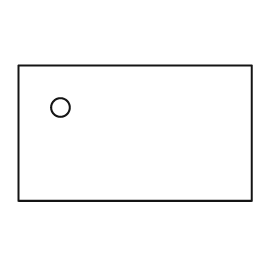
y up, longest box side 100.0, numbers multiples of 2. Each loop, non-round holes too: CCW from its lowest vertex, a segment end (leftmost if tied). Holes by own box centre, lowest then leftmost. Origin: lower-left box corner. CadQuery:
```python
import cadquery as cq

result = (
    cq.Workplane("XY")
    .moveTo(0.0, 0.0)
    .lineTo(100.0, 0.0)
    .lineTo(100.0, 58.0)
    .lineTo(0.0, 58.0)
    .close()
    .moveTo(18.0, 40.0)
    .circle(4.0)
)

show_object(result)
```